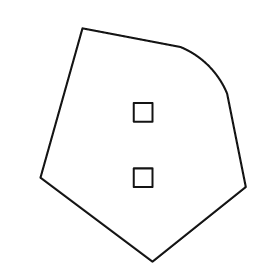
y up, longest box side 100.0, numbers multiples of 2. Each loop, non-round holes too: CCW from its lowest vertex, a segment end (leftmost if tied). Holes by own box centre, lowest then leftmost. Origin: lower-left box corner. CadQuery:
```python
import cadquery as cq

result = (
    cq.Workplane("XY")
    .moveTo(48.0, 0.0)
    .lineTo(88.0, 32.0)
    .lineTo(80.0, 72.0)
    .threePointArc((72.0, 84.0), (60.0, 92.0))
    .lineTo(18.0, 100.0)
    .lineTo(0.0, 36.0)
    .close()
    .moveTo(40.0, 32.0)
    .lineTo(48.0, 32.0)
    .lineTo(48.0, 40.0)
    .lineTo(40.0, 40.0)
    .close()
    .moveTo(40.0, 60.0)
    .lineTo(48.0, 60.0)
    .lineTo(48.0, 68.0)
    .lineTo(40.0, 68.0)
    .close()
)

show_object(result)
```